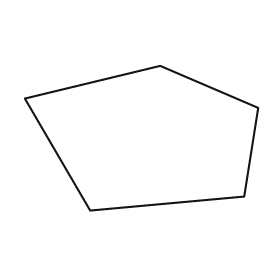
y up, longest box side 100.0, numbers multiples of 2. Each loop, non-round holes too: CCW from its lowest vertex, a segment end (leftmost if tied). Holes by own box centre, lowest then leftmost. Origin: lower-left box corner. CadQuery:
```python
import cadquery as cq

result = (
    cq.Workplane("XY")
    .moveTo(28.0, 0.0)
    .lineTo(94.0, 6.0)
    .lineTo(100.0, 44.0)
    .lineTo(58.0, 62.0)
    .lineTo(0.0, 48.0)
    .close()
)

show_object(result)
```